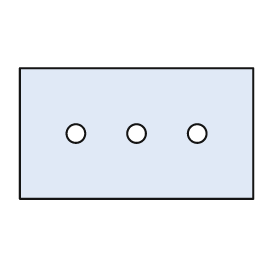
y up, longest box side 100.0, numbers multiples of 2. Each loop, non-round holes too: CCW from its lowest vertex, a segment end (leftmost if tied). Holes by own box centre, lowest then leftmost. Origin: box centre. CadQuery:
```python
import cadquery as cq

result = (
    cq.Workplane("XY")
    .moveTo(-50.0, -28.0)
    .lineTo(50.0, -28.0)
    .lineTo(50.0, 28.0)
    .lineTo(-50.0, 28.0)
    .close()
    .moveTo(-26.0, 0.0)
    .circle(4.0)
    .moveTo(0.0, 0.0)
    .circle(4.0)
    .moveTo(26.0, 0.0)
    .circle(4.0)
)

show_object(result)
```